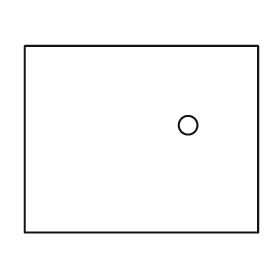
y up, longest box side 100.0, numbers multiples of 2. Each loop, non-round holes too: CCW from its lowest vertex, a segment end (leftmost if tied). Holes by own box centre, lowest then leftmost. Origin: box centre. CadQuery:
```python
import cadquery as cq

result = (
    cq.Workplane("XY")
    .moveTo(-50.0, -40.0)
    .lineTo(50.0, -40.0)
    .lineTo(50.0, 40.0)
    .lineTo(-50.0, 40.0)
    .close()
    .moveTo(20.0, 6.0)
    .circle(4.0)
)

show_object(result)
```